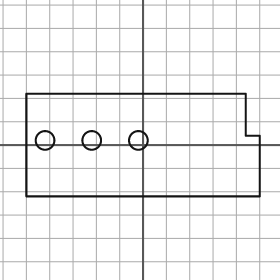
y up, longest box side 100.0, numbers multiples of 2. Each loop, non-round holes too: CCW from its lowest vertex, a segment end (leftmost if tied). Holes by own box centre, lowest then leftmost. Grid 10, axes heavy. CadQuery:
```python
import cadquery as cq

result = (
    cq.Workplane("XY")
    .moveTo(-50.0, -22.0)
    .lineTo(50.0, -22.0)
    .lineTo(50.0, 4.0)
    .lineTo(44.0, 4.0)
    .lineTo(44.0, 22.0)
    .lineTo(-50.0, 22.0)
    .close()
    .moveTo(-42.0, 2.0)
    .circle(4.0)
    .moveTo(-22.0, 2.0)
    .circle(4.0)
    .moveTo(-2.0, 2.0)
    .circle(4.0)
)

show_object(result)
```